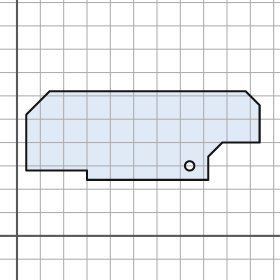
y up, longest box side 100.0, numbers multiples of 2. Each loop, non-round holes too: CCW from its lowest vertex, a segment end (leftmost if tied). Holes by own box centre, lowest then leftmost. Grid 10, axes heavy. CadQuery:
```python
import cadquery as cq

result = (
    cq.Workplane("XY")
    .moveTo(30.0, 24.0)
    .lineTo(82.0, 24.0)
    .lineTo(82.0, 34.0)
    .lineTo(88.0, 40.0)
    .lineTo(104.0, 40.0)
    .lineTo(104.0, 56.0)
    .lineTo(98.0, 62.0)
    .lineTo(14.0, 62.0)
    .lineTo(4.0, 52.0)
    .lineTo(4.0, 28.0)
    .lineTo(30.0, 28.0)
    .close()
    .moveTo(74.0, 30.0)
    .circle(2.0)
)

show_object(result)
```